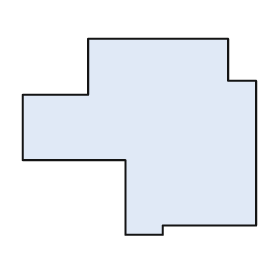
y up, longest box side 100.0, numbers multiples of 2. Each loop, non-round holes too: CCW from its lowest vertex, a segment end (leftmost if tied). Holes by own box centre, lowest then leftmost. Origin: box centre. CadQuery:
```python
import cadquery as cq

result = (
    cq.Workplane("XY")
    .moveTo(-6.0, -42.0)
    .lineTo(10.0, -42.0)
    .lineTo(10.0, -38.0)
    .lineTo(50.0, -38.0)
    .lineTo(50.0, 24.0)
    .lineTo(38.0, 24.0)
    .lineTo(38.0, 42.0)
    .lineTo(-22.0, 42.0)
    .lineTo(-22.0, 18.0)
    .lineTo(-50.0, 18.0)
    .lineTo(-50.0, -10.0)
    .lineTo(-6.0, -10.0)
    .close()
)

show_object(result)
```